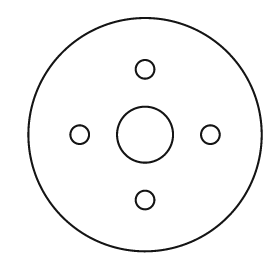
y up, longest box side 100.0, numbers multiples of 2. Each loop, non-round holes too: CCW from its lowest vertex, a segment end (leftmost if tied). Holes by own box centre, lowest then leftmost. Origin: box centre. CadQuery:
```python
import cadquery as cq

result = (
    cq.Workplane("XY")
    .moveTo(0.0, 0.0)
    .circle(50.0)
    .moveTo(0.0, -28.0)
    .circle(4.0)
    .moveTo(-28.0, 0.0)
    .circle(4.0)
    .moveTo(0.0, 0.0)
    .circle(12.0)
    .moveTo(28.0, 0.0)
    .circle(4.0)
    .moveTo(0.0, 28.0)
    .circle(4.0)
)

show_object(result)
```